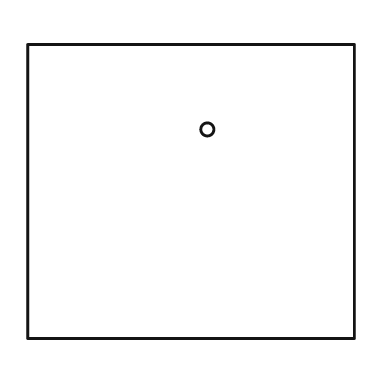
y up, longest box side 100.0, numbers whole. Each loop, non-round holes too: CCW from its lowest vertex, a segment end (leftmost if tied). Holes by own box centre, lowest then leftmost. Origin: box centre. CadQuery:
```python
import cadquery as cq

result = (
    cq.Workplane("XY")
    .moveTo(-50.0, -45.0)
    .lineTo(50.0, -45.0)
    .lineTo(50.0, 45.0)
    .lineTo(-50.0, 45.0)
    .close()
    .moveTo(5.0, 19.0)
    .circle(2.0)
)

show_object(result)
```